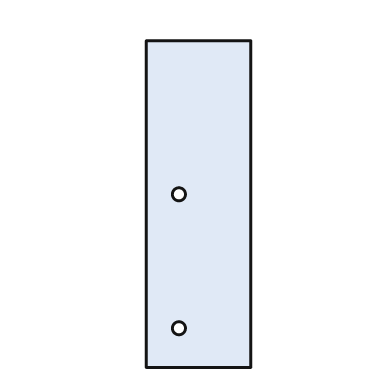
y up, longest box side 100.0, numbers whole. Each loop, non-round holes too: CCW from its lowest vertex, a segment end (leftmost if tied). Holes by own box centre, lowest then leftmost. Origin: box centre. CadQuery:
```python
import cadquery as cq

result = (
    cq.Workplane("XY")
    .moveTo(-16.0, -50.0)
    .lineTo(16.0, -50.0)
    .lineTo(16.0, 50.0)
    .lineTo(-16.0, 50.0)
    .close()
    .moveTo(-6.0, -38.0)
    .circle(2.0)
    .moveTo(-6.0, 3.0)
    .circle(2.0)
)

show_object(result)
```